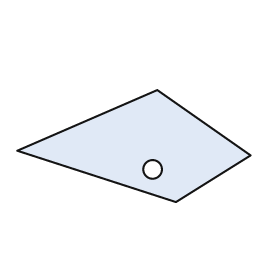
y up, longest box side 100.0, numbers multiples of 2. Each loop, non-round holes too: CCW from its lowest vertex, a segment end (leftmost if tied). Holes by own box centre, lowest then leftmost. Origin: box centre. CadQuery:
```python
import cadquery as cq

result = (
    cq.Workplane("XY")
    .moveTo(18.0, -24.0)
    .lineTo(50.0, -4.0)
    .lineTo(10.0, 24.0)
    .lineTo(-50.0, -2.0)
    .close()
    .moveTo(8.0, -10.0)
    .circle(4.0)
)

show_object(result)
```